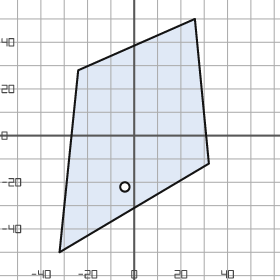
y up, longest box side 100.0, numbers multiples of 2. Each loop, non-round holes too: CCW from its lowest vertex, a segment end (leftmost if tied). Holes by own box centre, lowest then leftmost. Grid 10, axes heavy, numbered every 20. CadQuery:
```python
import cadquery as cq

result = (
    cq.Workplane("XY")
    .moveTo(-32.0, -50.0)
    .lineTo(32.0, -12.0)
    .lineTo(26.0, 50.0)
    .lineTo(-24.0, 28.0)
    .close()
    .moveTo(-4.0, -22.0)
    .circle(2.0)
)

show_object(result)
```